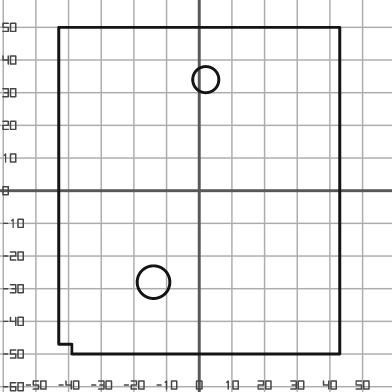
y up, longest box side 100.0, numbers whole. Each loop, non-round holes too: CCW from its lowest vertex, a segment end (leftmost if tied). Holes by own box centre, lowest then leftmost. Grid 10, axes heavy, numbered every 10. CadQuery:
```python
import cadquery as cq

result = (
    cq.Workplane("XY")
    .moveTo(-39.0, -50.0)
    .lineTo(43.0, -50.0)
    .lineTo(43.0, 50.0)
    .lineTo(-43.0, 50.0)
    .lineTo(-43.0, -47.0)
    .lineTo(-39.0, -47.0)
    .close()
    .moveTo(-14.0, -28.0)
    .circle(5.0)
    .moveTo(2.0, 34.0)
    .circle(4.0)
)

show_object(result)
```